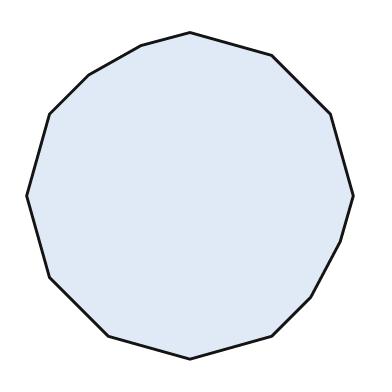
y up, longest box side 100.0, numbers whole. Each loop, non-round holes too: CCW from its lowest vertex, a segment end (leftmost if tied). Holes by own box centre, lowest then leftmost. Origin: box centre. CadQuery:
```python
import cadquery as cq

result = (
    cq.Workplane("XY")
    .moveTo(0.0, -50.0)
    .lineTo(25.0, -43.0)
    .lineTo(37.0, -31.0)
    .lineTo(46.0, -14.0)
    .lineTo(50.0, 0.0)
    .lineTo(43.0, 25.0)
    .lineTo(25.0, 43.0)
    .lineTo(0.0, 50.0)
    .lineTo(-15.0, 46.0)
    .lineTo(-31.0, 37.0)
    .lineTo(-43.0, 25.0)
    .lineTo(-50.0, 0.0)
    .lineTo(-43.0, -25.0)
    .lineTo(-25.0, -43.0)
    .close()
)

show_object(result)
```